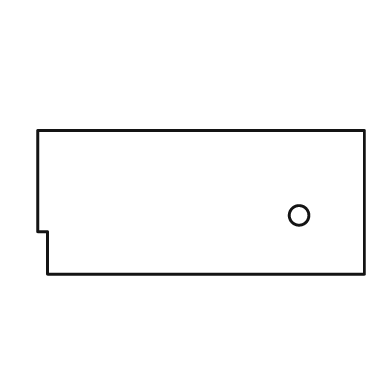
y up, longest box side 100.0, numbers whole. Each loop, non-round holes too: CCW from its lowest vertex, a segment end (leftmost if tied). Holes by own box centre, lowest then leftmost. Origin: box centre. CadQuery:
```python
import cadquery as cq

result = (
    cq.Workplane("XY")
    .moveTo(-47.0, -22.0)
    .lineTo(50.0, -22.0)
    .lineTo(50.0, 22.0)
    .lineTo(-50.0, 22.0)
    .lineTo(-50.0, -9.0)
    .lineTo(-47.0, -9.0)
    .close()
    .moveTo(30.0, -4.0)
    .circle(3.0)
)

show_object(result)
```